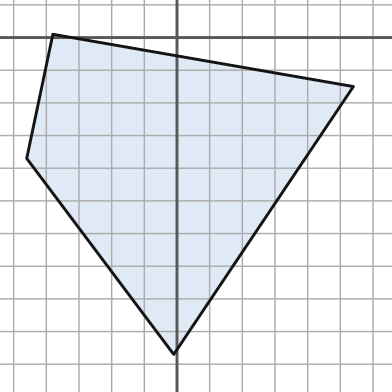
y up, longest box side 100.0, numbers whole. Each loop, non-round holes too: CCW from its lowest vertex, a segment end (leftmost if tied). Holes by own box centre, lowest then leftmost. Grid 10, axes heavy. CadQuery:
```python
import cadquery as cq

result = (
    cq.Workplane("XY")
    .moveTo(-1.0, -97.0)
    .lineTo(54.0, -15.0)
    .lineTo(-38.0, 1.0)
    .lineTo(-46.0, -37.0)
    .close()
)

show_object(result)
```